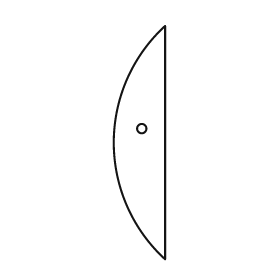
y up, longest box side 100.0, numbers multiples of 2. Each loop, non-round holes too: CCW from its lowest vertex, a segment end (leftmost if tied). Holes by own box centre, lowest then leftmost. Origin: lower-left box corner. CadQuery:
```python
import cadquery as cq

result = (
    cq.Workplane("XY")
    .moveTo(22.0, 0.0)
    .lineTo(22.0, 100.0)
    .threePointArc((0.0, 50.0), (22.0, 0.0))
    .close()
    .moveTo(12.0, 56.0)
    .circle(2.0)
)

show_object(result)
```